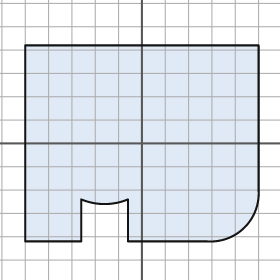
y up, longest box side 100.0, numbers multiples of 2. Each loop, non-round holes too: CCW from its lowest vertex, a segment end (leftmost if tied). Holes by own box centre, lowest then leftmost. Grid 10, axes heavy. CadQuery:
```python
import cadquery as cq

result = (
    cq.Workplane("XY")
    .moveTo(-50.0, -42.0)
    .lineTo(-26.0, -42.0)
    .lineTo(-26.0, -24.0)
    .threePointArc((-16.0, -26.0), (-6.0, -24.0))
    .lineTo(-6.0, -42.0)
    .lineTo(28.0, -42.0)
    .threePointArc((44.0, -36.0), (50.0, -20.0))
    .lineTo(50.0, 42.0)
    .lineTo(-50.0, 42.0)
    .close()
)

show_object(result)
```